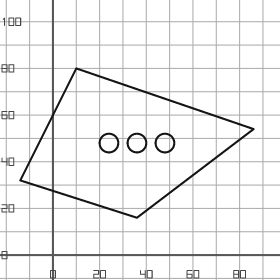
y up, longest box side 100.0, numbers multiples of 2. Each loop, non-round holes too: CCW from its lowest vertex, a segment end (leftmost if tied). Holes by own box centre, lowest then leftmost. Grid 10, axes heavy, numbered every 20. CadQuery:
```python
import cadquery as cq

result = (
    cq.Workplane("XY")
    .moveTo(36.0, 16.0)
    .lineTo(86.0, 54.0)
    .lineTo(10.0, 80.0)
    .lineTo(-14.0, 32.0)
    .close()
    .moveTo(24.0, 48.0)
    .circle(4.0)
    .moveTo(36.0, 48.0)
    .circle(4.0)
    .moveTo(48.0, 48.0)
    .circle(4.0)
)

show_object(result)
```